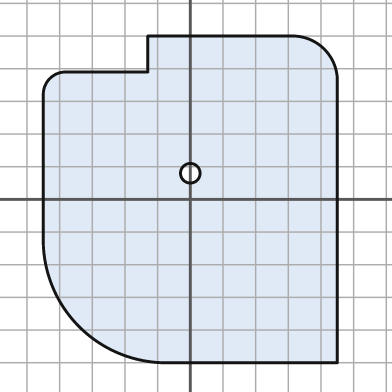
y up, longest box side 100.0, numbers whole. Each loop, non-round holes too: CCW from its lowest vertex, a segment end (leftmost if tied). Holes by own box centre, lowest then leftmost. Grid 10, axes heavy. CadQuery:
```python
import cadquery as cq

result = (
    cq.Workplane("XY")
    .moveTo(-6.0, -50.0)
    .lineTo(45.0, -50.0)
    .lineTo(45.0, 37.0)
    .threePointArc((41.0, 46.0), (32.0, 50.0))
    .lineTo(-13.0, 50.0)
    .lineTo(-13.0, 39.0)
    .lineTo(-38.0, 39.0)
    .threePointArc((-43.0, 37.0), (-45.0, 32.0))
    .lineTo(-45.0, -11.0)
    .threePointArc((-34.0, -39.0), (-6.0, -50.0))
    .close()
    .moveTo(0.0, 8.0)
    .circle(3.0)
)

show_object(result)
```